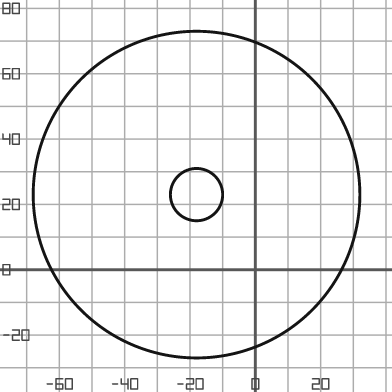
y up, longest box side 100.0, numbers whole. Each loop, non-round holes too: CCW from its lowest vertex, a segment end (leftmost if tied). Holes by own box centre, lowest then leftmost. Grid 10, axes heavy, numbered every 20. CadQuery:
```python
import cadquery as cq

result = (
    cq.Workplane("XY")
    .moveTo(-18.0, 23.0)
    .circle(50.0)
    .moveTo(-18.0, 23.0)
    .circle(8.0)
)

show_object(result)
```